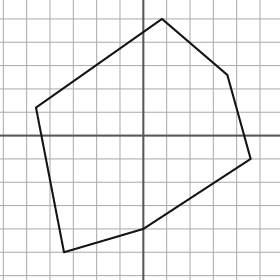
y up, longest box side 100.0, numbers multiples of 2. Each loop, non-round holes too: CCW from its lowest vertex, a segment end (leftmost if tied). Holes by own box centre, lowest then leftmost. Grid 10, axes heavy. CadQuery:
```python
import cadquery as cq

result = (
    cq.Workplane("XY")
    .moveTo(-34.0, -50.0)
    .lineTo(0.0, -40.0)
    .lineTo(46.0, -10.0)
    .lineTo(36.0, 26.0)
    .lineTo(8.0, 50.0)
    .lineTo(-46.0, 12.0)
    .close()
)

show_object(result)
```